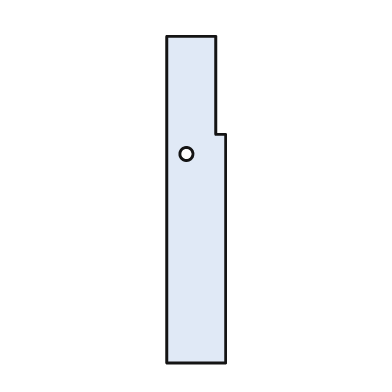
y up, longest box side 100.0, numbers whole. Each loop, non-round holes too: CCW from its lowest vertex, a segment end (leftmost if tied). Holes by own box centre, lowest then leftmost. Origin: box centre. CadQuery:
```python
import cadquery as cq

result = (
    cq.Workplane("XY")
    .moveTo(-9.0, -50.0)
    .lineTo(9.0, -50.0)
    .lineTo(9.0, 20.0)
    .lineTo(6.0, 20.0)
    .lineTo(6.0, 50.0)
    .lineTo(-9.0, 50.0)
    .close()
    .moveTo(-3.0, 14.0)
    .circle(2.0)
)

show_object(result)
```